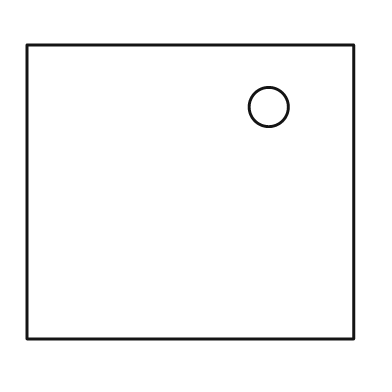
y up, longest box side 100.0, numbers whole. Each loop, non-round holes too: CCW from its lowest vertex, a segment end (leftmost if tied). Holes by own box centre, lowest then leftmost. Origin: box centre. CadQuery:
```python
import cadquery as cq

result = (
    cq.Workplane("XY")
    .moveTo(-50.0, -45.0)
    .lineTo(50.0, -45.0)
    .lineTo(50.0, 45.0)
    .lineTo(-50.0, 45.0)
    .close()
    .moveTo(24.0, 26.0)
    .circle(6.0)
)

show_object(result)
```